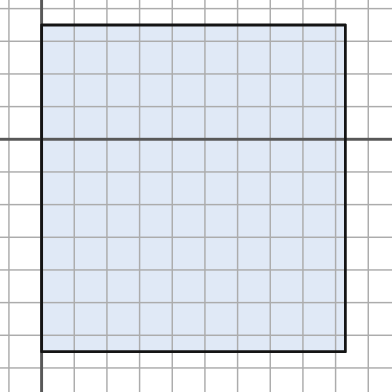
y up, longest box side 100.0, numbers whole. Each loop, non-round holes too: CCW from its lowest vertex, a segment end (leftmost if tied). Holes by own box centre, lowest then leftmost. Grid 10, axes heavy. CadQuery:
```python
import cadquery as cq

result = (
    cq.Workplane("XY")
    .moveTo(0.0, -65.0)
    .lineTo(93.0, -65.0)
    .lineTo(93.0, 35.0)
    .lineTo(0.0, 35.0)
    .close()
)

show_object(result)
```